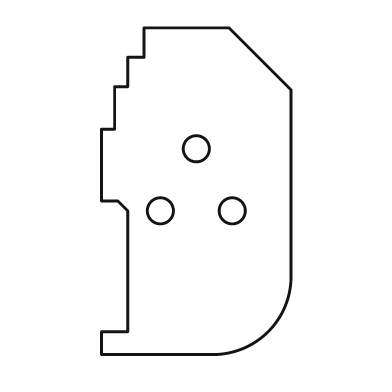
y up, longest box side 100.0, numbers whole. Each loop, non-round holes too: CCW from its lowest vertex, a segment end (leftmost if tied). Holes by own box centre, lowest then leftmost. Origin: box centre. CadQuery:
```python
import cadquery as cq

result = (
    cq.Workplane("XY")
    .moveTo(-29.0, -50.0)
    .lineTo(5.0, -50.0)
    .threePointArc((22.0, -43.0), (29.0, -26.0))
    .lineTo(29.0, 31.0)
    .lineTo(10.0, 50.0)
    .lineTo(-16.0, 50.0)
    .lineTo(-16.0, 41.0)
    .lineTo(-21.0, 41.0)
    .lineTo(-21.0, 32.0)
    .lineTo(-25.0, 32.0)
    .lineTo(-25.0, 19.0)
    .lineTo(-29.0, 19.0)
    .lineTo(-29.0, -3.0)
    .lineTo(-24.0, -3.0)
    .lineTo(-21.0, -6.0)
    .lineTo(-21.0, -43.0)
    .lineTo(-29.0, -43.0)
    .close()
    .moveTo(-11.0, -6.0)
    .circle(4.0)
    .moveTo(11.0, -6.0)
    .circle(4.0)
    .moveTo(0.0, 13.0)
    .circle(4.0)
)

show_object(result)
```